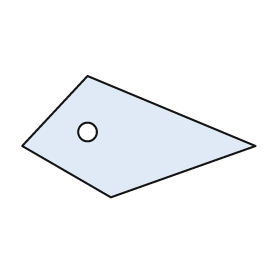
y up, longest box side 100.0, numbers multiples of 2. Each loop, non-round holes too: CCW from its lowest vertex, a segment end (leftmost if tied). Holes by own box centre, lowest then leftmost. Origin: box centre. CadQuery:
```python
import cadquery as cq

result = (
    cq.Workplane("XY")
    .moveTo(-12.0, -26.0)
    .lineTo(50.0, -4.0)
    .lineTo(-22.0, 26.0)
    .lineTo(-50.0, -4.0)
    .close()
    .moveTo(-22.0, 2.0)
    .circle(4.0)
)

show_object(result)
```